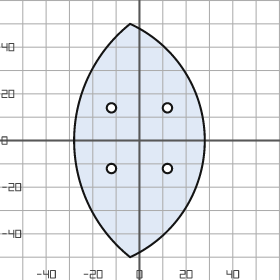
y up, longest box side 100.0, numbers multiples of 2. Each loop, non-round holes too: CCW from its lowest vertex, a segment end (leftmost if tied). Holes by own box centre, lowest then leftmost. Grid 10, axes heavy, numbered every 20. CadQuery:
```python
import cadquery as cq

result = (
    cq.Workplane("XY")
    .moveTo(-4.0, -50.0)
    .threePointArc((28.0, 0.0), (-4.0, 50.0))
    .threePointArc((-28.0, 0.0), (-4.0, -50.0))
    .close()
    .moveTo(-12.0, -12.0)
    .circle(2.0)
    .moveTo(12.0, -12.0)
    .circle(2.0)
    .moveTo(-12.0, 14.0)
    .circle(2.0)
    .moveTo(12.0, 14.0)
    .circle(2.0)
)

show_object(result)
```